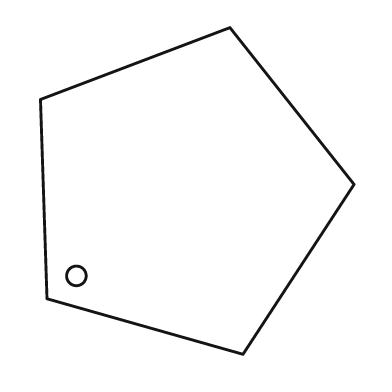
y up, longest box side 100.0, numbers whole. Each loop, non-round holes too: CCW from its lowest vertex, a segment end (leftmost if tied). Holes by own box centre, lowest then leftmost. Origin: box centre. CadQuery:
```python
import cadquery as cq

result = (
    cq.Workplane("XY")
    .moveTo(14.0, -50.0)
    .lineTo(48.0, 2.0)
    .lineTo(10.0, 50.0)
    .lineTo(-48.0, 28.0)
    .lineTo(-46.0, -33.0)
    .close()
    .moveTo(-37.0, -26.0)
    .circle(3.0)
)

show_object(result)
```